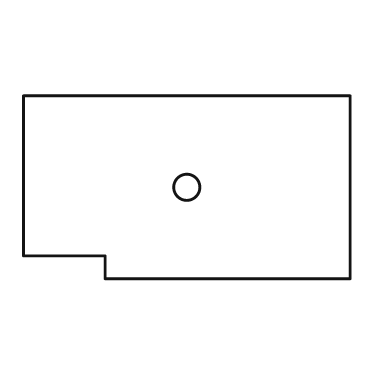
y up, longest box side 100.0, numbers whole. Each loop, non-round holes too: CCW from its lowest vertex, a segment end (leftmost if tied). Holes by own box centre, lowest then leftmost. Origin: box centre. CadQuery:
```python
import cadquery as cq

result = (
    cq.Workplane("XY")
    .moveTo(-25.0, -28.0)
    .lineTo(50.0, -28.0)
    .lineTo(50.0, 28.0)
    .lineTo(-50.0, 28.0)
    .lineTo(-50.0, -21.0)
    .lineTo(-25.0, -21.0)
    .close()
    .moveTo(0.0, 0.0)
    .circle(4.0)
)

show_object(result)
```